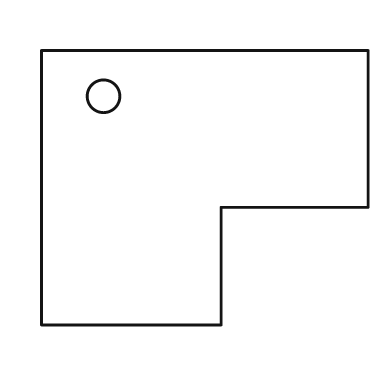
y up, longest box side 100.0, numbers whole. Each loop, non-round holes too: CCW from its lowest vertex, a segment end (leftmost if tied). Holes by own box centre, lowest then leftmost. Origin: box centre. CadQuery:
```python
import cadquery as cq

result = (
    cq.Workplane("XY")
    .moveTo(-50.0, -42.0)
    .lineTo(5.0, -42.0)
    .lineTo(5.0, -6.0)
    .lineTo(50.0, -6.0)
    .lineTo(50.0, 42.0)
    .lineTo(-50.0, 42.0)
    .close()
    .moveTo(-31.0, 28.0)
    .circle(5.0)
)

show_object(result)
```